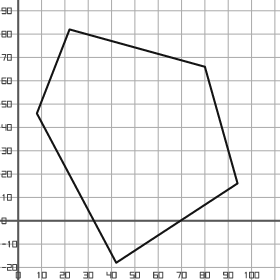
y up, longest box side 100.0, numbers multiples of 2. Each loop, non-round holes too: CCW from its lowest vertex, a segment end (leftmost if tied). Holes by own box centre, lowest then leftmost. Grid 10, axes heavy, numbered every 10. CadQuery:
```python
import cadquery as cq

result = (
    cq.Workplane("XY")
    .moveTo(42.0, -18.0)
    .lineTo(94.0, 16.0)
    .lineTo(80.0, 66.0)
    .lineTo(22.0, 82.0)
    .lineTo(8.0, 46.0)
    .close()
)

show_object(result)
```